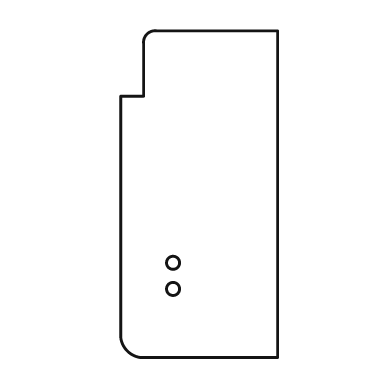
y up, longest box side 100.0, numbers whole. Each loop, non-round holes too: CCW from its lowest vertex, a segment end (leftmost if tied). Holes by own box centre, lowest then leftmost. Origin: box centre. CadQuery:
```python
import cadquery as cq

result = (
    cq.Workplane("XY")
    .moveTo(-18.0, -50.0)
    .lineTo(24.0, -50.0)
    .lineTo(24.0, 50.0)
    .lineTo(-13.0, 50.0)
    .threePointArc((-16.0, 49.0), (-17.0, 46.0))
    .lineTo(-17.0, 30.0)
    .lineTo(-24.0, 30.0)
    .lineTo(-24.0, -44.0)
    .threePointArc((-22.0, -48.0), (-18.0, -50.0))
    .close()
    .moveTo(-8.0, -29.0)
    .circle(2.0)
    .moveTo(-8.0, -21.0)
    .circle(2.0)
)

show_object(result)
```